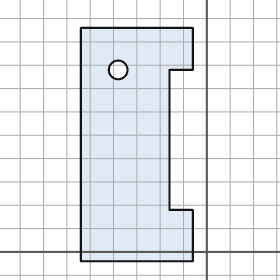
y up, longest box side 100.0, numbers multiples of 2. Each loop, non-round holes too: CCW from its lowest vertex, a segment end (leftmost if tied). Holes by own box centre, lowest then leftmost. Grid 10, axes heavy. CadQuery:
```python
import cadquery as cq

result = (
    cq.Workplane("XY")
    .moveTo(-54.0, -4.0)
    .lineTo(-6.0, -4.0)
    .lineTo(-6.0, 18.0)
    .lineTo(-16.0, 18.0)
    .lineTo(-16.0, 78.0)
    .lineTo(-6.0, 78.0)
    .lineTo(-6.0, 96.0)
    .lineTo(-54.0, 96.0)
    .close()
    .moveTo(-38.0, 78.0)
    .circle(4.0)
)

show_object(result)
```